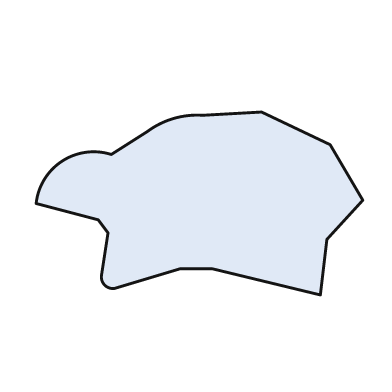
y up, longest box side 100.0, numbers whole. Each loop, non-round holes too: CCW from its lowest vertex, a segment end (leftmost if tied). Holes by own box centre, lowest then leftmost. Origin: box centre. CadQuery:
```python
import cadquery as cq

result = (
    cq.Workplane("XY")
    .moveTo(37.0, -28.0)
    .lineTo(39.0, -11.0)
    .lineTo(50.0, 1.0)
    .lineTo(40.0, 18.0)
    .lineTo(19.0, 28.0)
    .lineTo(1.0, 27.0)
    .threePointArc((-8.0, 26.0), (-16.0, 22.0))
    .lineTo(-27.0, 15.0)
    .threePointArc((-42.0, 13.0), (-50.0, 0.0))
    .lineTo(-31.0, -5.0)
    .lineTo(-28.0, -9.0)
    .lineTo(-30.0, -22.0)
    .threePointArc((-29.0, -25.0), (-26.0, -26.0))
    .lineTo(-6.0, -20.0)
    .lineTo(4.0, -20.0)
    .close()
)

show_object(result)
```